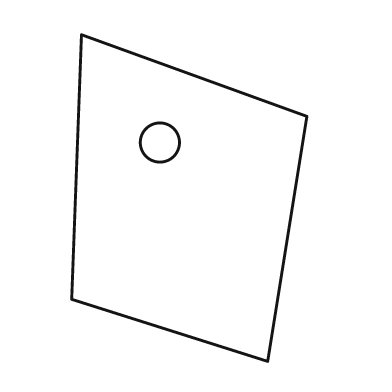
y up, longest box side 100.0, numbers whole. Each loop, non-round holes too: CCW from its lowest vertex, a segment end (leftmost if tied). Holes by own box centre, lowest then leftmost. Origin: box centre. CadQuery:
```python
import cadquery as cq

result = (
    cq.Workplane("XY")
    .moveTo(24.0, -50.0)
    .lineTo(36.0, 25.0)
    .lineTo(-33.0, 50.0)
    .lineTo(-36.0, -31.0)
    .close()
    .moveTo(-9.0, 17.0)
    .circle(6.0)
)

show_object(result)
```